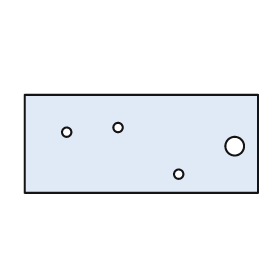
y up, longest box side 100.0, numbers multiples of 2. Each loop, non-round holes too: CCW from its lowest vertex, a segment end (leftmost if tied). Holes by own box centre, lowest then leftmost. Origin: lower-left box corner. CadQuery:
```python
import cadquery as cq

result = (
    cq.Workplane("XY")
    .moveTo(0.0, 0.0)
    .lineTo(100.0, 0.0)
    .lineTo(100.0, 42.0)
    .lineTo(0.0, 42.0)
    .close()
    .moveTo(66.0, 8.0)
    .circle(2.0)
    .moveTo(90.0, 20.0)
    .circle(4.0)
    .moveTo(18.0, 26.0)
    .circle(2.0)
    .moveTo(40.0, 28.0)
    .circle(2.0)
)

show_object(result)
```